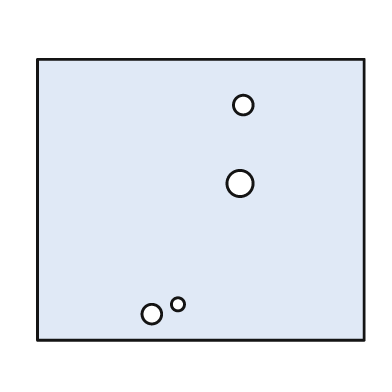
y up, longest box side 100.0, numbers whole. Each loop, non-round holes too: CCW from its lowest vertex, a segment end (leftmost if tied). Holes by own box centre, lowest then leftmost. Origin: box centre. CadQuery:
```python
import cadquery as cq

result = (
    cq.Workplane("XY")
    .moveTo(-50.0, -43.0)
    .lineTo(50.0, -43.0)
    .lineTo(50.0, 43.0)
    .lineTo(-50.0, 43.0)
    .close()
    .moveTo(-15.0, -35.0)
    .circle(3.0)
    .moveTo(-7.0, -32.0)
    .circle(2.0)
    .moveTo(12.0, 5.0)
    .circle(4.0)
    .moveTo(13.0, 29.0)
    .circle(3.0)
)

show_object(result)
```